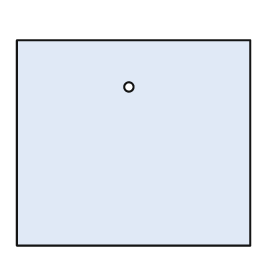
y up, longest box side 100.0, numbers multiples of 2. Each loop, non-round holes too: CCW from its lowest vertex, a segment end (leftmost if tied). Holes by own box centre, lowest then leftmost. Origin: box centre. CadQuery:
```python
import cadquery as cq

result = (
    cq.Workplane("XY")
    .moveTo(-50.0, -44.0)
    .lineTo(50.0, -44.0)
    .lineTo(50.0, 44.0)
    .lineTo(-50.0, 44.0)
    .close()
    .moveTo(-2.0, 24.0)
    .circle(2.0)
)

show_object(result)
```